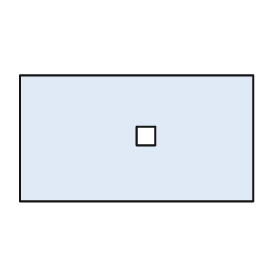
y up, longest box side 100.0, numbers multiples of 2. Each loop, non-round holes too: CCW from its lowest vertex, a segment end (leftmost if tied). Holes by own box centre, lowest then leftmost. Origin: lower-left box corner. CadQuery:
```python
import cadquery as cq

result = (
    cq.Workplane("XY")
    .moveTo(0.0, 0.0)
    .lineTo(100.0, 0.0)
    .lineTo(100.0, 54.0)
    .lineTo(0.0, 54.0)
    .close()
    .moveTo(50.0, 24.0)
    .lineTo(58.0, 24.0)
    .lineTo(58.0, 32.0)
    .lineTo(50.0, 32.0)
    .close()
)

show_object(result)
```